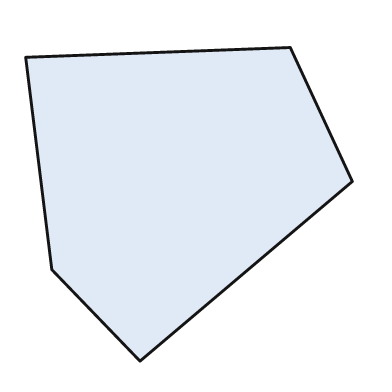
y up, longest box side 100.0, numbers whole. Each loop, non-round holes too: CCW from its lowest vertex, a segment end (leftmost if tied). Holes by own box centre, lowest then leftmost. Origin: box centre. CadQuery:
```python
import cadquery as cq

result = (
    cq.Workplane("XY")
    .moveTo(-15.0, -48.0)
    .lineTo(50.0, 7.0)
    .lineTo(31.0, 48.0)
    .lineTo(-50.0, 45.0)
    .lineTo(-42.0, -20.0)
    .close()
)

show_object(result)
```